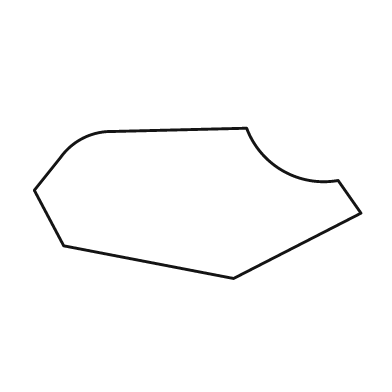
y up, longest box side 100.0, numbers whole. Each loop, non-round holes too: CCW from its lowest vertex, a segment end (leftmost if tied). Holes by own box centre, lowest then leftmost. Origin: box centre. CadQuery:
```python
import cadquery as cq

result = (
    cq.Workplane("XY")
    .moveTo(11.0, -23.0)
    .lineTo(50.0, -3.0)
    .lineTo(43.0, 7.0)
    .threePointArc((26.0, 10.0), (15.0, 23.0))
    .lineTo(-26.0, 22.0)
    .threePointArc((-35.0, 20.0), (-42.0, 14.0))
    .lineTo(-50.0, 4.0)
    .lineTo(-41.0, -13.0)
    .close()
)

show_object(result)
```